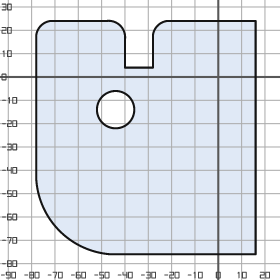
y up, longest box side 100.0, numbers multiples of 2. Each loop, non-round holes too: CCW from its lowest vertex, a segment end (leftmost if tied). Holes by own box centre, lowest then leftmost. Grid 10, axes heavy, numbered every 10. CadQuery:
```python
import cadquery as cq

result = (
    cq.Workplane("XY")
    .moveTo(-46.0, -76.0)
    .lineTo(16.0, -76.0)
    .lineTo(16.0, 24.0)
    .lineTo(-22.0, 24.0)
    .threePointArc((-26.0, 22.0), (-28.0, 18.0))
    .lineTo(-28.0, 4.0)
    .lineTo(-40.0, 4.0)
    .lineTo(-40.0, 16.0)
    .threePointArc((-42.0, 22.0), (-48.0, 24.0))
    .lineTo(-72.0, 24.0)
    .threePointArc((-76.0, 22.0), (-78.0, 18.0))
    .lineTo(-78.0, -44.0)
    .threePointArc((-68.0, -66.0), (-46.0, -76.0))
    .close()
    .moveTo(-44.0, -14.0)
    .circle(8.0)
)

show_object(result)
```